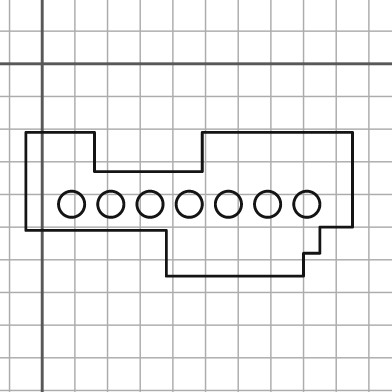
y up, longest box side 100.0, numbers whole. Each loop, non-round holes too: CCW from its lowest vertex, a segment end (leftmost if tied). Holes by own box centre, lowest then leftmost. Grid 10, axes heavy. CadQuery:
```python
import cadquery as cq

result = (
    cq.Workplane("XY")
    .moveTo(38.0, -65.0)
    .lineTo(80.0, -65.0)
    .lineTo(80.0, -58.0)
    .lineTo(85.0, -58.0)
    .lineTo(85.0, -50.0)
    .lineTo(95.0, -50.0)
    .lineTo(95.0, -21.0)
    .lineTo(49.0, -21.0)
    .lineTo(49.0, -33.0)
    .lineTo(16.0, -33.0)
    .lineTo(16.0, -21.0)
    .lineTo(-5.0, -21.0)
    .lineTo(-5.0, -51.0)
    .lineTo(38.0, -51.0)
    .close()
    .moveTo(9.0, -43.0)
    .circle(4.0)
    .moveTo(21.0, -43.0)
    .circle(4.0)
    .moveTo(33.0, -43.0)
    .circle(4.0)
    .moveTo(45.0, -43.0)
    .circle(4.0)
    .moveTo(57.0, -43.0)
    .circle(4.0)
    .moveTo(69.0, -43.0)
    .circle(4.0)
    .moveTo(81.0, -43.0)
    .circle(4.0)
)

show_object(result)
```